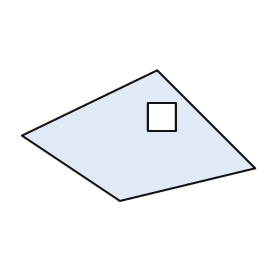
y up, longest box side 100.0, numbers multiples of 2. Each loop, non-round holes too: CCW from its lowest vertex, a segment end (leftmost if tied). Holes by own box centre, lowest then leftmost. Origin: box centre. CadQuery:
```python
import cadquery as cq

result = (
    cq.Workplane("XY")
    .moveTo(-8.0, -28.0)
    .lineTo(50.0, -14.0)
    .lineTo(8.0, 28.0)
    .lineTo(-50.0, 0.0)
    .close()
    .moveTo(4.0, 2.0)
    .lineTo(16.0, 2.0)
    .lineTo(16.0, 14.0)
    .lineTo(4.0, 14.0)
    .close()
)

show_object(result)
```